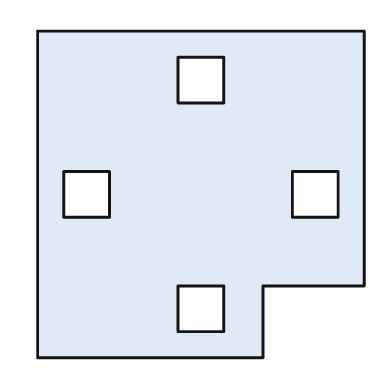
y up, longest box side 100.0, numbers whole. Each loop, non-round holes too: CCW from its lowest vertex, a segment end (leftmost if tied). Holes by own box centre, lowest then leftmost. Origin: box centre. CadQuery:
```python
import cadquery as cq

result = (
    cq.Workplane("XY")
    .moveTo(-50.0, -50.0)
    .lineTo(19.0, -50.0)
    .lineTo(19.0, -28.0)
    .lineTo(50.0, -28.0)
    .lineTo(50.0, 50.0)
    .lineTo(-50.0, 50.0)
    .close()
    .moveTo(-7.0, -42.0)
    .lineTo(7.0, -42.0)
    .lineTo(7.0, -28.0)
    .lineTo(-7.0, -28.0)
    .close()
    .moveTo(-42.0, -7.0)
    .lineTo(-28.0, -7.0)
    .lineTo(-28.0, 7.0)
    .lineTo(-42.0, 7.0)
    .close()
    .moveTo(28.0, -7.0)
    .lineTo(42.0, -7.0)
    .lineTo(42.0, 7.0)
    .lineTo(28.0, 7.0)
    .close()
    .moveTo(-7.0, 28.0)
    .lineTo(7.0, 28.0)
    .lineTo(7.0, 42.0)
    .lineTo(-7.0, 42.0)
    .close()
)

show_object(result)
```